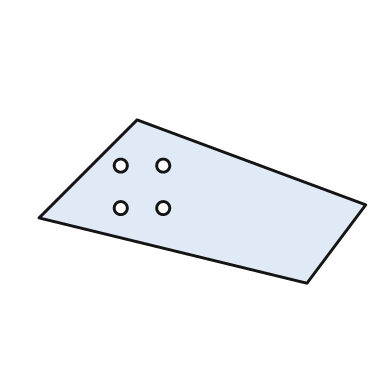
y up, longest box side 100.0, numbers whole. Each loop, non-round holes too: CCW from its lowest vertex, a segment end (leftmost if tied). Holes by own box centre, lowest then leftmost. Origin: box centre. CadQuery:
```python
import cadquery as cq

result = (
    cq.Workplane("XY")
    .moveTo(32.0, -25.0)
    .lineTo(50.0, -1.0)
    .lineTo(-20.0, 25.0)
    .lineTo(-50.0, -5.0)
    .close()
    .moveTo(-25.0, -2.0)
    .circle(2.0)
    .moveTo(-12.0, -2.0)
    .circle(2.0)
    .moveTo(-25.0, 11.0)
    .circle(2.0)
    .moveTo(-12.0, 11.0)
    .circle(2.0)
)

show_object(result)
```